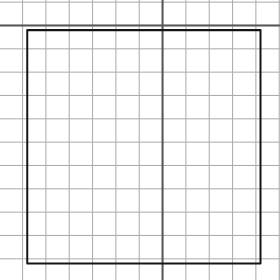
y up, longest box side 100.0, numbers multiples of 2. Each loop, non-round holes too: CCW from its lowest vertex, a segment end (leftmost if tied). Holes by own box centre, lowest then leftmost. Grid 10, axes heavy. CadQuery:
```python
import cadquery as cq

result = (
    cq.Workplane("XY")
    .moveTo(-58.0, -102.0)
    .lineTo(42.0, -102.0)
    .lineTo(42.0, -2.0)
    .lineTo(-58.0, -2.0)
    .close()
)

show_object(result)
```